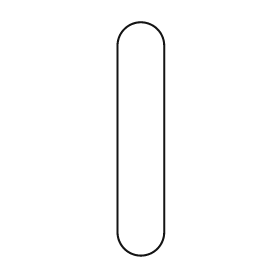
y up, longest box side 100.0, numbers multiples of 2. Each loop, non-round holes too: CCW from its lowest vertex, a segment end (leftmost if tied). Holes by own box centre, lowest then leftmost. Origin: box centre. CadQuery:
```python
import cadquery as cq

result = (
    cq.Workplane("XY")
    .moveTo(-10.0, -40.0)
    .threePointArc((0.0, -50.0), (10.0, -40.0))
    .lineTo(10.0, 40.0)
    .threePointArc((0.0, 50.0), (-10.0, 40.0))
    .close()
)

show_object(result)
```